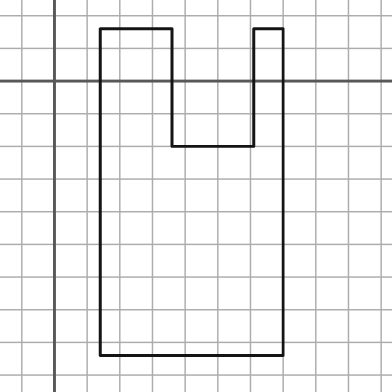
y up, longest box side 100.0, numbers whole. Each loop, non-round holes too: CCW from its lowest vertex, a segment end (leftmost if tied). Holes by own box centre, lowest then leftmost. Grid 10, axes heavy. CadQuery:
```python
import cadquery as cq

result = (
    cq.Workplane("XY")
    .moveTo(14.0, -84.0)
    .lineTo(70.0, -84.0)
    .lineTo(70.0, 16.0)
    .lineTo(61.0, 16.0)
    .lineTo(61.0, -20.0)
    .lineTo(36.0, -20.0)
    .lineTo(36.0, 16.0)
    .lineTo(14.0, 16.0)
    .close()
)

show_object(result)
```